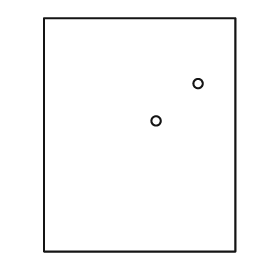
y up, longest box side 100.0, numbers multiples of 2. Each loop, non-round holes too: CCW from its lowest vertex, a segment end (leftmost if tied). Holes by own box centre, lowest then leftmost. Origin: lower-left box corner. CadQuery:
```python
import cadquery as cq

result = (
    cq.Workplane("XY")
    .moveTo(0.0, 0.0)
    .lineTo(82.0, 0.0)
    .lineTo(82.0, 100.0)
    .lineTo(0.0, 100.0)
    .close()
    .moveTo(48.0, 56.0)
    .circle(2.0)
    .moveTo(66.0, 72.0)
    .circle(2.0)
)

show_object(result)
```